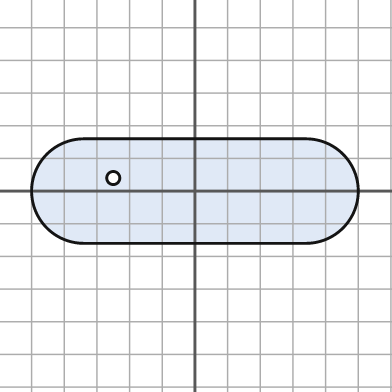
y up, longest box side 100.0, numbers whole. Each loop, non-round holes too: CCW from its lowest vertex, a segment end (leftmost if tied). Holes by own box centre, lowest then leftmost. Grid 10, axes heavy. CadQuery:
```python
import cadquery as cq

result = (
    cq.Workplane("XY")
    .moveTo(-34.0, -16.0)
    .lineTo(34.0, -16.0)
    .threePointArc((50.0, 0.0), (34.0, 16.0))
    .lineTo(-34.0, 16.0)
    .threePointArc((-50.0, 0.0), (-34.0, -16.0))
    .close()
    .moveTo(-25.0, 4.0)
    .circle(2.0)
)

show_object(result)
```